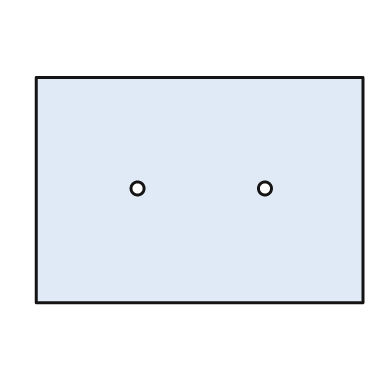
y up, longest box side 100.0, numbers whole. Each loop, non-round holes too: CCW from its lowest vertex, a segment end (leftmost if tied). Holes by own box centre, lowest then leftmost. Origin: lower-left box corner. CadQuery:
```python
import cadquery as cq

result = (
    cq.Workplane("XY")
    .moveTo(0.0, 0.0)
    .lineTo(100.0, 0.0)
    .lineTo(100.0, 69.0)
    .lineTo(0.0, 69.0)
    .close()
    .moveTo(31.0, 35.0)
    .circle(2.0)
    .moveTo(70.0, 35.0)
    .circle(2.0)
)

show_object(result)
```